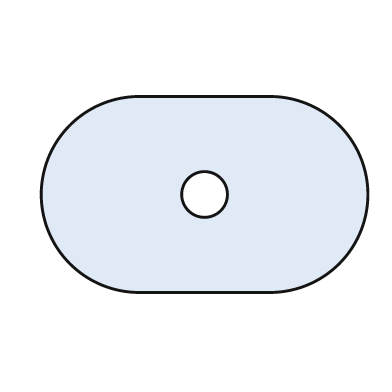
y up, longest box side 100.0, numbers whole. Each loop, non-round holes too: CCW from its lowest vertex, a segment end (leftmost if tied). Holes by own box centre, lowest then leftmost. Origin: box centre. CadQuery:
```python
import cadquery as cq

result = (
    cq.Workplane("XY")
    .moveTo(-20.0, -30.0)
    .lineTo(20.0, -30.0)
    .threePointArc((50.0, 0.0), (20.0, 30.0))
    .lineTo(-20.0, 30.0)
    .threePointArc((-50.0, 0.0), (-20.0, -30.0))
    .close()
    .moveTo(0.0, 0.0)
    .circle(7.0)
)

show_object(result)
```